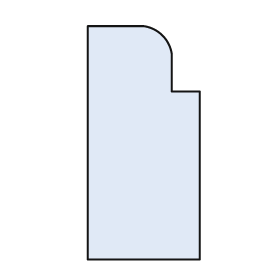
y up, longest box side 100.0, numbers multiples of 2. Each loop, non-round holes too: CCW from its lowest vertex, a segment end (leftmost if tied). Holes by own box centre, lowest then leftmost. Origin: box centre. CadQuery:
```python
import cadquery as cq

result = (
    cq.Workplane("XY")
    .moveTo(-24.0, -50.0)
    .lineTo(24.0, -50.0)
    .lineTo(24.0, 22.0)
    .lineTo(12.0, 22.0)
    .lineTo(12.0, 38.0)
    .threePointArc((8.0, 46.0), (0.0, 50.0))
    .lineTo(-24.0, 50.0)
    .close()
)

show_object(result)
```